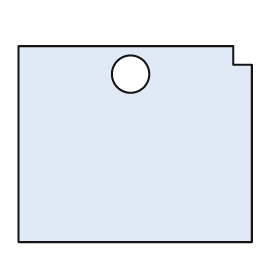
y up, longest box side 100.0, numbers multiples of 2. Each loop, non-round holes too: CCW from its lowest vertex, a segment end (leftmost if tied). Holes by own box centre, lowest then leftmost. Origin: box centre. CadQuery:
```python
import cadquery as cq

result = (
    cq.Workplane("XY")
    .moveTo(-50.0, -42.0)
    .lineTo(50.0, -42.0)
    .lineTo(50.0, 34.0)
    .lineTo(42.0, 34.0)
    .lineTo(42.0, 42.0)
    .lineTo(-50.0, 42.0)
    .close()
    .moveTo(-2.0, 30.0)
    .circle(8.0)
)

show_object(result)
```